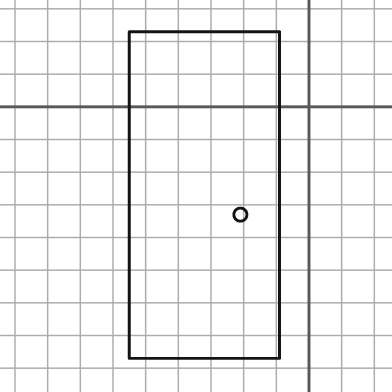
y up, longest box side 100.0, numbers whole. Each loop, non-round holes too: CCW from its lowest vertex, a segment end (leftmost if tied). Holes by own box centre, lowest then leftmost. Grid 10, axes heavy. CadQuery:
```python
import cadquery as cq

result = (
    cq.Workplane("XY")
    .moveTo(-55.0, -77.0)
    .lineTo(-9.0, -77.0)
    .lineTo(-9.0, 23.0)
    .lineTo(-55.0, 23.0)
    .close()
    .moveTo(-21.0, -33.0)
    .circle(2.0)
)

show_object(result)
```